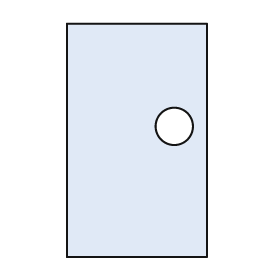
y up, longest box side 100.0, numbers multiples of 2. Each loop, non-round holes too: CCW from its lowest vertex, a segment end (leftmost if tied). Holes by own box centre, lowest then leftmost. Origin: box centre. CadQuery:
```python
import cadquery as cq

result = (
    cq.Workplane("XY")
    .moveTo(-30.0, -50.0)
    .lineTo(30.0, -50.0)
    .lineTo(30.0, 50.0)
    .lineTo(-30.0, 50.0)
    .close()
    .moveTo(16.0, 6.0)
    .circle(8.0)
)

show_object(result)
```